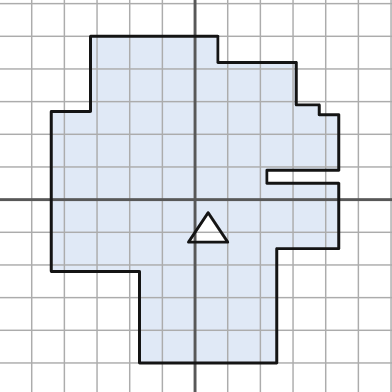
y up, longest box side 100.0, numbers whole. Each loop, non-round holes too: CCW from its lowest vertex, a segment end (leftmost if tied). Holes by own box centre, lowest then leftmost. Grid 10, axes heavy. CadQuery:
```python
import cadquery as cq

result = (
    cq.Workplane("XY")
    .moveTo(-17.0, -50.0)
    .lineTo(25.0, -50.0)
    .lineTo(25.0, -15.0)
    .lineTo(44.0, -15.0)
    .lineTo(44.0, 5.0)
    .lineTo(22.0, 5.0)
    .lineTo(22.0, 9.0)
    .lineTo(44.0, 9.0)
    .lineTo(44.0, 26.0)
    .lineTo(38.0, 26.0)
    .lineTo(38.0, 29.0)
    .lineTo(31.0, 29.0)
    .lineTo(31.0, 42.0)
    .lineTo(7.0, 42.0)
    .lineTo(7.0, 50.0)
    .lineTo(-32.0, 50.0)
    .lineTo(-32.0, 27.0)
    .lineTo(-44.0, 27.0)
    .lineTo(-44.0, -22.0)
    .lineTo(-17.0, -22.0)
    .close()
    .moveTo(-2.0, -13.0)
    .lineTo(10.0, -13.0)
    .lineTo(4.0, -4.0)
    .close()
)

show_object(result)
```